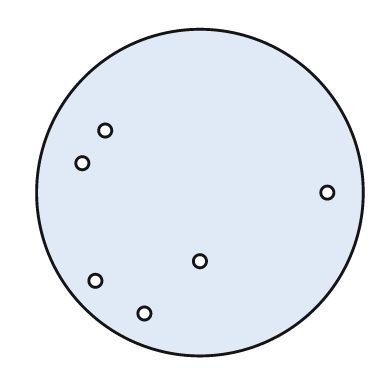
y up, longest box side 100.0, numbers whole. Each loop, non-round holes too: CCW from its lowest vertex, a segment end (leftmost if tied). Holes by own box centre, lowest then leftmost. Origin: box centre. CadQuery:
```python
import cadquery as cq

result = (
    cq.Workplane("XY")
    .moveTo(0.0, 0.0)
    .circle(50.0)
    .moveTo(-17.0, -37.0)
    .circle(2.0)
    .moveTo(-32.0, -27.0)
    .circle(2.0)
    .moveTo(0.0, -21.0)
    .circle(2.0)
    .moveTo(39.0, 0.0)
    .circle(2.0)
    .moveTo(-36.0, 9.0)
    .circle(2.0)
    .moveTo(-29.0, 19.0)
    .circle(2.0)
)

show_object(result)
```